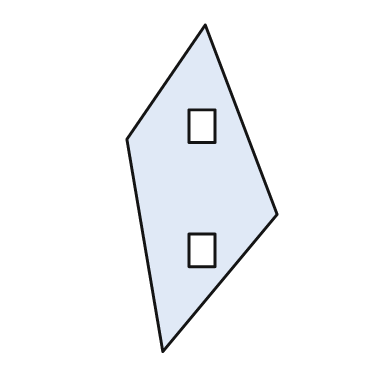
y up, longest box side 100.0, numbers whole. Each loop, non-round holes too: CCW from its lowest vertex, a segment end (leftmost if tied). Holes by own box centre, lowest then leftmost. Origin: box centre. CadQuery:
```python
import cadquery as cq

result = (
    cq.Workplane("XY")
    .moveTo(-12.0, -50.0)
    .lineTo(23.0, -8.0)
    .lineTo(1.0, 50.0)
    .lineTo(-23.0, 15.0)
    .close()
    .moveTo(-4.0, -24.0)
    .lineTo(4.0, -24.0)
    .lineTo(4.0, -14.0)
    .lineTo(-4.0, -14.0)
    .close()
    .moveTo(-4.0, 14.0)
    .lineTo(4.0, 14.0)
    .lineTo(4.0, 24.0)
    .lineTo(-4.0, 24.0)
    .close()
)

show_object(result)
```